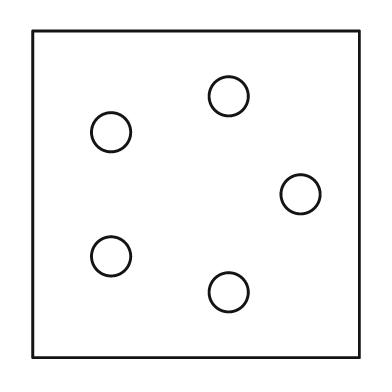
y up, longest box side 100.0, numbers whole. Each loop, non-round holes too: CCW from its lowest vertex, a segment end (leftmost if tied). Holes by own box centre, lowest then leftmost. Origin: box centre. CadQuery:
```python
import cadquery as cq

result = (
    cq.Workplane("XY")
    .moveTo(-50.0, -50.0)
    .lineTo(50.0, -50.0)
    .lineTo(50.0, 50.0)
    .lineTo(-50.0, 50.0)
    .close()
    .moveTo(10.0, -30.0)
    .circle(6.0)
    .moveTo(-26.0, -19.0)
    .circle(6.0)
    .moveTo(32.0, 0.0)
    .circle(6.0)
    .moveTo(-26.0, 19.0)
    .circle(6.0)
    .moveTo(10.0, 30.0)
    .circle(6.0)
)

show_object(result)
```